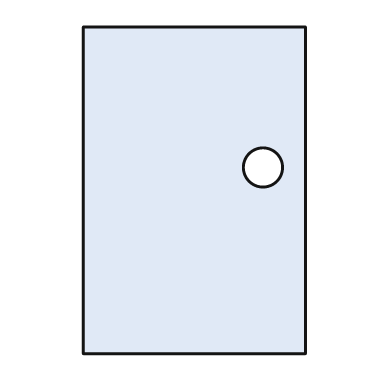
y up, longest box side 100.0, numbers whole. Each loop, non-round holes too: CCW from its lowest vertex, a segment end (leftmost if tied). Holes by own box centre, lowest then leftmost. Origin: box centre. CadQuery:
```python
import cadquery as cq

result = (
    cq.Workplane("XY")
    .moveTo(-34.0, -50.0)
    .lineTo(34.0, -50.0)
    .lineTo(34.0, 50.0)
    .lineTo(-34.0, 50.0)
    .close()
    .moveTo(21.0, 7.0)
    .circle(6.0)
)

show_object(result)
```